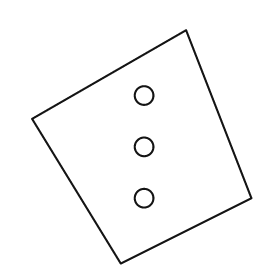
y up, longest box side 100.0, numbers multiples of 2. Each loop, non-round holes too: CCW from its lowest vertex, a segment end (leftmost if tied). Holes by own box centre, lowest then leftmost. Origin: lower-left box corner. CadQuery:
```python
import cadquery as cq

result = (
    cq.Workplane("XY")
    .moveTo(38.0, 0.0)
    .lineTo(94.0, 28.0)
    .lineTo(66.0, 100.0)
    .lineTo(0.0, 62.0)
    .close()
    .moveTo(48.0, 28.0)
    .circle(4.0)
    .moveTo(48.0, 50.0)
    .circle(4.0)
    .moveTo(48.0, 72.0)
    .circle(4.0)
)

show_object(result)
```